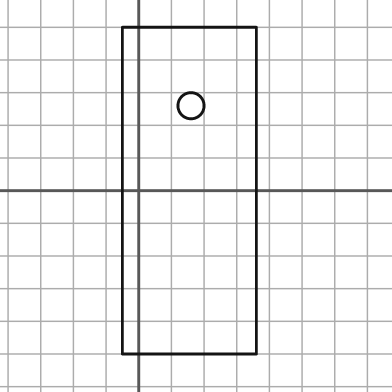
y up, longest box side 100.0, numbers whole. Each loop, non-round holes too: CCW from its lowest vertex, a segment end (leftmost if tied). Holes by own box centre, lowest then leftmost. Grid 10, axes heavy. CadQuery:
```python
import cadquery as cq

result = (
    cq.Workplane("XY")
    .moveTo(-5.0, -50.0)
    .lineTo(36.0, -50.0)
    .lineTo(36.0, 50.0)
    .lineTo(-5.0, 50.0)
    .close()
    .moveTo(16.0, 26.0)
    .circle(4.0)
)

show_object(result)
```